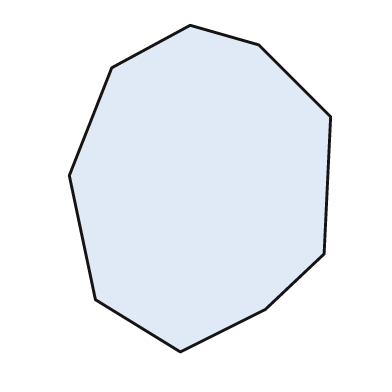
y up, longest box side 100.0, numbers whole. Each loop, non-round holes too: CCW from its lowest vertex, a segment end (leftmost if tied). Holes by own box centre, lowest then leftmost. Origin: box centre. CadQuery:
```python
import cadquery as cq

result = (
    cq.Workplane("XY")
    .moveTo(-6.0, -50.0)
    .lineTo(20.0, -37.0)
    .lineTo(38.0, -20.0)
    .lineTo(40.0, 22.0)
    .lineTo(18.0, 44.0)
    .lineTo(-3.0, 50.0)
    .lineTo(-27.0, 37.0)
    .lineTo(-40.0, 4.0)
    .lineTo(-32.0, -34.0)
    .close()
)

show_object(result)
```